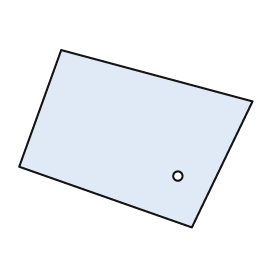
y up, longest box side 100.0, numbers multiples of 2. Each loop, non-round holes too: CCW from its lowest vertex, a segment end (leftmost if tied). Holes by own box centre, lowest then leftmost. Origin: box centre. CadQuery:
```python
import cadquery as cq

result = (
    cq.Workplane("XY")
    .moveTo(24.0, -38.0)
    .lineTo(50.0, 16.0)
    .lineTo(-32.0, 38.0)
    .lineTo(-50.0, -12.0)
    .close()
    .moveTo(18.0, -16.0)
    .circle(2.0)
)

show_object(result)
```